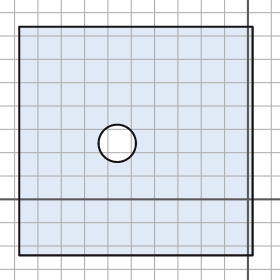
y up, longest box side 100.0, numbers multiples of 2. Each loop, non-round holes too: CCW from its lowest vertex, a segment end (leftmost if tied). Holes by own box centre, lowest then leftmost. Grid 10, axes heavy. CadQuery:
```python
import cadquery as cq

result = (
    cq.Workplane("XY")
    .moveTo(-98.0, -24.0)
    .lineTo(2.0, -24.0)
    .lineTo(2.0, 74.0)
    .lineTo(-98.0, 74.0)
    .close()
    .moveTo(-56.0, 24.0)
    .circle(8.0)
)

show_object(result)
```